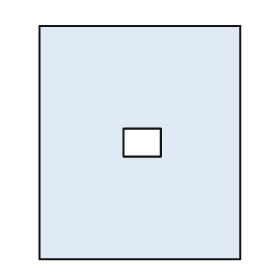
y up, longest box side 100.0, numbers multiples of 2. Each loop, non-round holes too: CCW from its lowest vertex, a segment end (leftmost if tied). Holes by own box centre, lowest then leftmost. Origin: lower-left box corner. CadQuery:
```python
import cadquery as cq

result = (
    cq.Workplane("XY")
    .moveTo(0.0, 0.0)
    .lineTo(86.0, 0.0)
    .lineTo(86.0, 100.0)
    .lineTo(0.0, 100.0)
    .close()
    .moveTo(36.0, 44.0)
    .lineTo(52.0, 44.0)
    .lineTo(52.0, 56.0)
    .lineTo(36.0, 56.0)
    .close()
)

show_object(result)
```